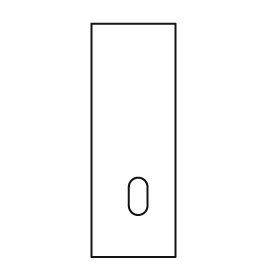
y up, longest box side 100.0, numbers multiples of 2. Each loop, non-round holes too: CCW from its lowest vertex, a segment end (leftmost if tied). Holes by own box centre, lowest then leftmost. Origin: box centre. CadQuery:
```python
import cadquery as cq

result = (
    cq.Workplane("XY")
    .moveTo(-18.0, -50.0)
    .lineTo(18.0, -50.0)
    .lineTo(18.0, 50.0)
    .lineTo(-18.0, 50.0)
    .close()
    .moveTo(-2.0, -28.0)
    .threePointArc((2.0, -32.0), (6.0, -28.0))
    .lineTo(6.0, -20.0)
    .threePointArc((2.0, -16.0), (-2.0, -20.0))
    .close()
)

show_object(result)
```